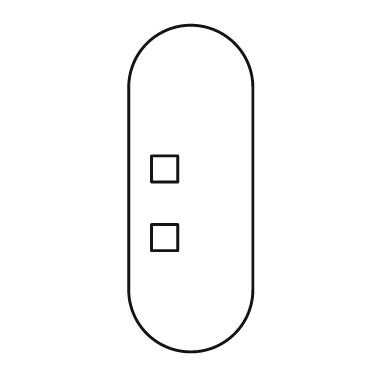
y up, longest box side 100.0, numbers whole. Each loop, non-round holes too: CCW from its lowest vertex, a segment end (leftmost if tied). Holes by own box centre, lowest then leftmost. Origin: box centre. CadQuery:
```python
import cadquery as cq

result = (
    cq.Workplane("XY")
    .moveTo(-19.0, -31.0)
    .threePointArc((0.0, -50.0), (19.0, -31.0))
    .lineTo(19.0, 31.0)
    .threePointArc((0.0, 50.0), (-19.0, 31.0))
    .close()
    .moveTo(-12.0, -19.0)
    .lineTo(-4.0, -19.0)
    .lineTo(-4.0, -11.0)
    .lineTo(-12.0, -11.0)
    .close()
    .moveTo(-12.0, 2.0)
    .lineTo(-4.0, 2.0)
    .lineTo(-4.0, 10.0)
    .lineTo(-12.0, 10.0)
    .close()
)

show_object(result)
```